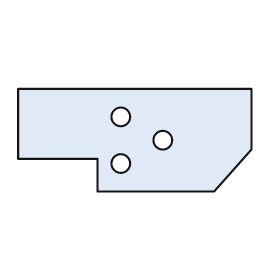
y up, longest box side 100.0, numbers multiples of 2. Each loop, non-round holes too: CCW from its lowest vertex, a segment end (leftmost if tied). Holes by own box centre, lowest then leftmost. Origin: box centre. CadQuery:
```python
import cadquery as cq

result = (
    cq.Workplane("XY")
    .moveTo(-16.0, -22.0)
    .lineTo(34.0, -22.0)
    .lineTo(50.0, -4.0)
    .lineTo(50.0, 22.0)
    .lineTo(-50.0, 22.0)
    .lineTo(-50.0, -8.0)
    .lineTo(-16.0, -8.0)
    .close()
    .moveTo(-6.0, -10.0)
    .circle(4.0)
    .moveTo(12.0, 0.0)
    .circle(4.0)
    .moveTo(-6.0, 10.0)
    .circle(4.0)
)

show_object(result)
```